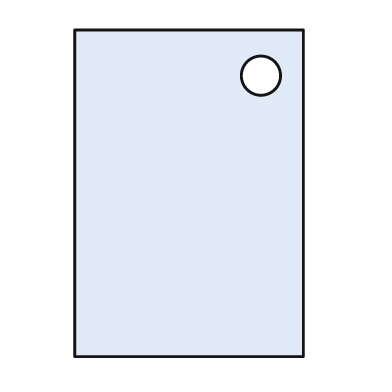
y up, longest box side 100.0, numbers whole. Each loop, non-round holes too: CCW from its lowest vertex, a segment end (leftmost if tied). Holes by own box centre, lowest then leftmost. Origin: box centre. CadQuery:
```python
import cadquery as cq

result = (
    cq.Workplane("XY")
    .moveTo(-35.0, -50.0)
    .lineTo(35.0, -50.0)
    .lineTo(35.0, 50.0)
    .lineTo(-35.0, 50.0)
    .close()
    .moveTo(22.0, 36.0)
    .circle(6.0)
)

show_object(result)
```